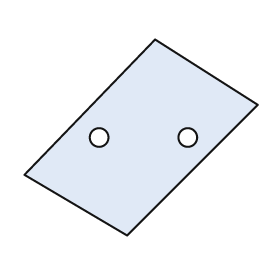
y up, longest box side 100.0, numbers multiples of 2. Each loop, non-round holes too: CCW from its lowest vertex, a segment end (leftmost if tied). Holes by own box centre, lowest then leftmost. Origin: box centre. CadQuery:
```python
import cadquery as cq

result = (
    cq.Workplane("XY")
    .moveTo(-6.0, -42.0)
    .lineTo(50.0, 14.0)
    .lineTo(6.0, 42.0)
    .lineTo(-50.0, -16.0)
    .close()
    .moveTo(-18.0, 0.0)
    .circle(4.0)
    .moveTo(20.0, 0.0)
    .circle(4.0)
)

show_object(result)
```